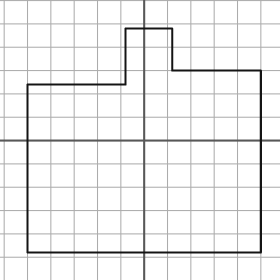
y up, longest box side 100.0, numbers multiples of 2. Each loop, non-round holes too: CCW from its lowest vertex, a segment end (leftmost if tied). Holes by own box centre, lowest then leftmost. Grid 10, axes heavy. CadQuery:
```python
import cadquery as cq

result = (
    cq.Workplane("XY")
    .moveTo(-50.0, -48.0)
    .lineTo(50.0, -48.0)
    .lineTo(50.0, 30.0)
    .lineTo(12.0, 30.0)
    .lineTo(12.0, 48.0)
    .lineTo(-8.0, 48.0)
    .lineTo(-8.0, 24.0)
    .lineTo(-50.0, 24.0)
    .close()
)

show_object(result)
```